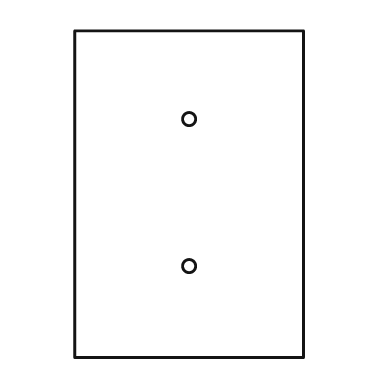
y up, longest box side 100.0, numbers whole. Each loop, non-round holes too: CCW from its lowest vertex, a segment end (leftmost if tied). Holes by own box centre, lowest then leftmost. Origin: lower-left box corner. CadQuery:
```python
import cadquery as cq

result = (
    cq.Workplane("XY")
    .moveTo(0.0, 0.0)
    .lineTo(70.0, 0.0)
    .lineTo(70.0, 100.0)
    .lineTo(0.0, 100.0)
    .close()
    .moveTo(35.0, 28.0)
    .circle(2.0)
    .moveTo(35.0, 73.0)
    .circle(2.0)
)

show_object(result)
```